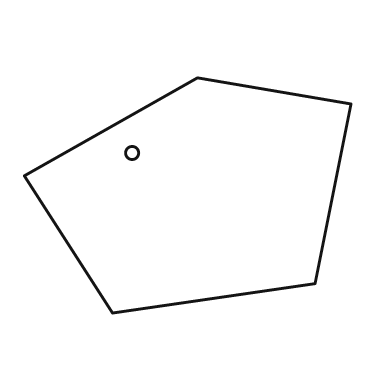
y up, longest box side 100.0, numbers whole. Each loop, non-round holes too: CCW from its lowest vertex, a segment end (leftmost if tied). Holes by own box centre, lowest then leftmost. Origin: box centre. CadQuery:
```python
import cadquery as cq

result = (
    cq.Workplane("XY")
    .moveTo(-23.0, -36.0)
    .lineTo(39.0, -27.0)
    .lineTo(50.0, 28.0)
    .lineTo(3.0, 36.0)
    .lineTo(-50.0, 6.0)
    .close()
    .moveTo(-17.0, 13.0)
    .circle(2.0)
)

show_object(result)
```